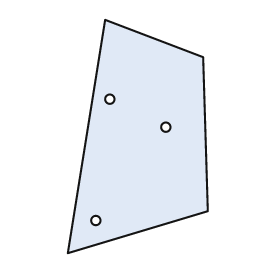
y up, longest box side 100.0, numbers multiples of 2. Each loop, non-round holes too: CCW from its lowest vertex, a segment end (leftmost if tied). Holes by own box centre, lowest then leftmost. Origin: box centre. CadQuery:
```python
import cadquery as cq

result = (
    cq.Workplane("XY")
    .moveTo(-30.0, -50.0)
    .lineTo(30.0, -32.0)
    .lineTo(28.0, 34.0)
    .lineTo(-14.0, 50.0)
    .close()
    .moveTo(-18.0, -36.0)
    .circle(2.0)
    .moveTo(12.0, 4.0)
    .circle(2.0)
    .moveTo(-12.0, 16.0)
    .circle(2.0)
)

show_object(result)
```